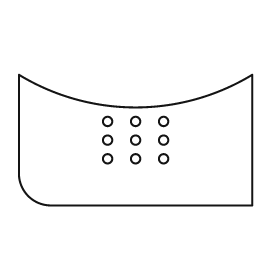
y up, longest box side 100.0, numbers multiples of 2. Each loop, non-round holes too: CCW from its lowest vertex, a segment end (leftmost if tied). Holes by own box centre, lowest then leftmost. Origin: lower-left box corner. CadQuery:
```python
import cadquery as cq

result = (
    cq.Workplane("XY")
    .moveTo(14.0, 0.0)
    .lineTo(100.0, 0.0)
    .lineTo(100.0, 56.0)
    .threePointArc((50.0, 42.0), (0.0, 56.0))
    .lineTo(0.0, 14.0)
    .threePointArc((4.0, 4.0), (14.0, 0.0))
    .close()
    .moveTo(38.0, 20.0)
    .circle(2.0)
    .moveTo(50.0, 20.0)
    .circle(2.0)
    .moveTo(62.0, 20.0)
    .circle(2.0)
    .moveTo(38.0, 28.0)
    .circle(2.0)
    .moveTo(50.0, 28.0)
    .circle(2.0)
    .moveTo(62.0, 28.0)
    .circle(2.0)
    .moveTo(38.0, 36.0)
    .circle(2.0)
    .moveTo(50.0, 36.0)
    .circle(2.0)
    .moveTo(62.0, 36.0)
    .circle(2.0)
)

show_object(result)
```